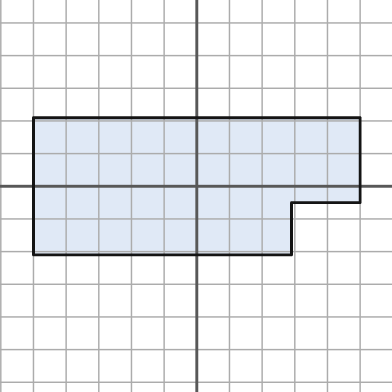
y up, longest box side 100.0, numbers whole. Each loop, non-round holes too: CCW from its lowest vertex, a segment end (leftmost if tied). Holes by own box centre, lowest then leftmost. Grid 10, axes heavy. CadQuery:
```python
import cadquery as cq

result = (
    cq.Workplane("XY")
    .moveTo(-50.0, -21.0)
    .lineTo(29.0, -21.0)
    .lineTo(29.0, -5.0)
    .lineTo(50.0, -5.0)
    .lineTo(50.0, 21.0)
    .lineTo(-50.0, 21.0)
    .close()
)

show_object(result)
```